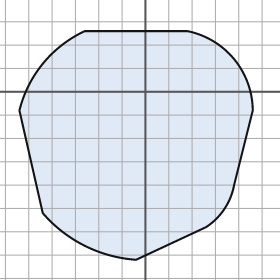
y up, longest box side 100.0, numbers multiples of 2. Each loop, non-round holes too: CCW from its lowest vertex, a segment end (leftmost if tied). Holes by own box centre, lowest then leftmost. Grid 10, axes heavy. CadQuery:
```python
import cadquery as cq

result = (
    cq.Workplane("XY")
    .moveTo(-4.0, -72.0)
    .lineTo(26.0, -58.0)
    .threePointArc((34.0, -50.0), (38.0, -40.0))
    .lineTo(46.0, -8.0)
    .threePointArc((38.0, 14.0), (18.0, 26.0))
    .lineTo(-26.0, 26.0)
    .threePointArc((-44.0, 12.0), (-54.0, -8.0))
    .lineTo(-44.0, -52.0)
    .threePointArc((-26.0, -66.0), (-4.0, -72.0))
    .close()
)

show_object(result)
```